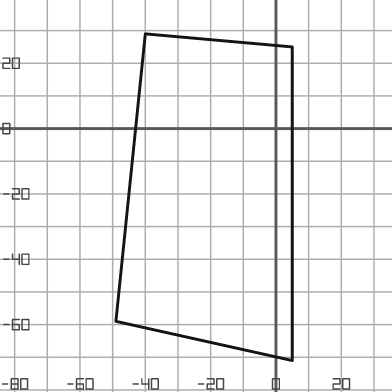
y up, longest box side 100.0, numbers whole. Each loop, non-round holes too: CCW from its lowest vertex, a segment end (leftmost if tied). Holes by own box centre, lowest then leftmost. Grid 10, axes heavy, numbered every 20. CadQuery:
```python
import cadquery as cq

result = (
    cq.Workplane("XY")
    .moveTo(5.0, -71.0)
    .lineTo(5.0, 25.0)
    .lineTo(-40.0, 29.0)
    .lineTo(-49.0, -59.0)
    .close()
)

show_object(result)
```